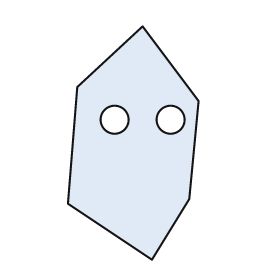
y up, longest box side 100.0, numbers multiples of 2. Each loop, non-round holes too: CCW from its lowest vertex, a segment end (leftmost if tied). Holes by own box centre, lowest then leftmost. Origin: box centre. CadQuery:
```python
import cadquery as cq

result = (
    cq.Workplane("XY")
    .moveTo(8.0, -50.0)
    .lineTo(24.0, -24.0)
    .lineTo(28.0, 18.0)
    .lineTo(4.0, 50.0)
    .lineTo(-24.0, 24.0)
    .lineTo(-28.0, -26.0)
    .close()
    .moveTo(-8.0, 10.0)
    .circle(6.0)
    .moveTo(16.0, 10.0)
    .circle(6.0)
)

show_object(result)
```